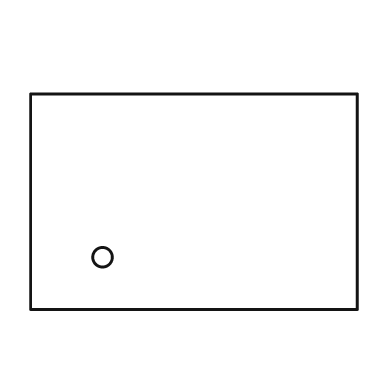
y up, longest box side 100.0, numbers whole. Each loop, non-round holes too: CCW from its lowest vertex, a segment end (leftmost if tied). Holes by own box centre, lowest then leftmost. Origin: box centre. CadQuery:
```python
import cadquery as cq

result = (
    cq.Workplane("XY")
    .moveTo(-50.0, -33.0)
    .lineTo(50.0, -33.0)
    .lineTo(50.0, 33.0)
    .lineTo(-50.0, 33.0)
    .close()
    .moveTo(-28.0, -17.0)
    .circle(3.0)
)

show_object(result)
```